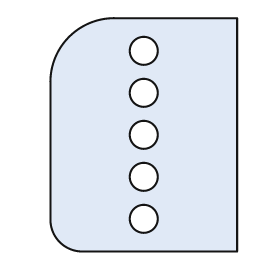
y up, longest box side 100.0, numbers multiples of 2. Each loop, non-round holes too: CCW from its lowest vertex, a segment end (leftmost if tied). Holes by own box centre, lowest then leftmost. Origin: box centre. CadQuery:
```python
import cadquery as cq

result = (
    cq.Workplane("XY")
    .moveTo(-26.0, -50.0)
    .lineTo(40.0, -50.0)
    .lineTo(40.0, 50.0)
    .lineTo(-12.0, 50.0)
    .threePointArc((-32.0, 42.0), (-40.0, 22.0))
    .lineTo(-40.0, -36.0)
    .threePointArc((-36.0, -46.0), (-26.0, -50.0))
    .close()
    .moveTo(0.0, -36.0)
    .circle(6.0)
    .moveTo(0.0, -18.0)
    .circle(6.0)
    .moveTo(0.0, 0.0)
    .circle(6.0)
    .moveTo(0.0, 18.0)
    .circle(6.0)
    .moveTo(0.0, 36.0)
    .circle(6.0)
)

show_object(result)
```